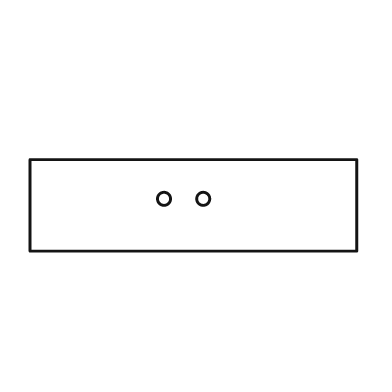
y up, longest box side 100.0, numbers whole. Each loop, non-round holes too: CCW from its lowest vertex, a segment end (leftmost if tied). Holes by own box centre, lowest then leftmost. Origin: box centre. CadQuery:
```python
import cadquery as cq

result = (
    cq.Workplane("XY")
    .moveTo(-50.0, -14.0)
    .lineTo(50.0, -14.0)
    .lineTo(50.0, 14.0)
    .lineTo(-50.0, 14.0)
    .close()
    .moveTo(-9.0, 2.0)
    .circle(2.0)
    .moveTo(3.0, 2.0)
    .circle(2.0)
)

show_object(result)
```